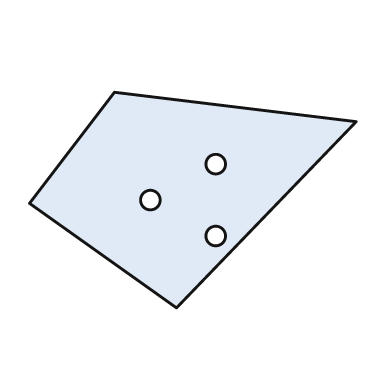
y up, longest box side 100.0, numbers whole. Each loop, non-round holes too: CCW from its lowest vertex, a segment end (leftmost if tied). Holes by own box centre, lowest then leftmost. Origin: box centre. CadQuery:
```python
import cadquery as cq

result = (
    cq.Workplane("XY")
    .moveTo(-5.0, -33.0)
    .lineTo(50.0, 24.0)
    .lineTo(-24.0, 33.0)
    .lineTo(-50.0, -1.0)
    .close()
    .moveTo(7.0, -11.0)
    .circle(3.0)
    .moveTo(-13.0, 0.0)
    .circle(3.0)
    .moveTo(7.0, 11.0)
    .circle(3.0)
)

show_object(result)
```